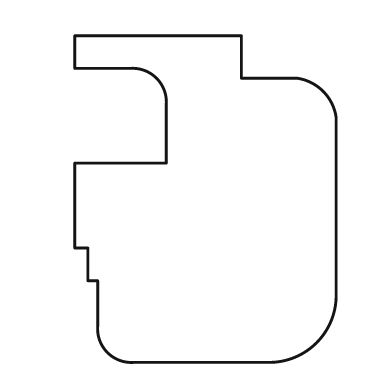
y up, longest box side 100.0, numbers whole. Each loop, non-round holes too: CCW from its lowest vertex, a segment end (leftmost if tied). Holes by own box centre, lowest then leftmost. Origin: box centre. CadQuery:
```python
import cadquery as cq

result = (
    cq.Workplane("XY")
    .moveTo(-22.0, -50.0)
    .lineTo(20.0, -50.0)
    .threePointArc((34.0, -44.0), (40.0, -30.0))
    .lineTo(40.0, 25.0)
    .threePointArc((36.0, 33.0), (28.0, 37.0))
    .lineTo(11.0, 37.0)
    .lineTo(11.0, 50.0)
    .lineTo(-40.0, 50.0)
    .lineTo(-40.0, 40.0)
    .lineTo(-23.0, 40.0)
    .threePointArc((-15.0, 37.0), (-12.0, 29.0))
    .lineTo(-12.0, 11.0)
    .lineTo(-40.0, 11.0)
    .lineTo(-40.0, -15.0)
    .lineTo(-36.0, -15.0)
    .lineTo(-36.0, -25.0)
    .lineTo(-33.0, -25.0)
    .lineTo(-33.0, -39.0)
    .threePointArc((-30.0, -47.0), (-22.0, -50.0))
    .close()
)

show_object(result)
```